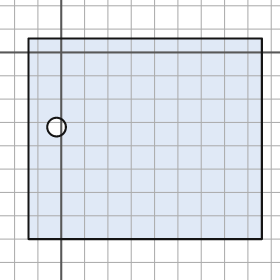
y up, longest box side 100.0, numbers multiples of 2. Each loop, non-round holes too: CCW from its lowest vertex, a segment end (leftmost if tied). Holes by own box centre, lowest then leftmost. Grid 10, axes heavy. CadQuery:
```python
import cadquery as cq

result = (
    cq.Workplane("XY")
    .moveTo(-14.0, -80.0)
    .lineTo(86.0, -80.0)
    .lineTo(86.0, 6.0)
    .lineTo(-14.0, 6.0)
    .close()
    .moveTo(-2.0, -32.0)
    .circle(4.0)
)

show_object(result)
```